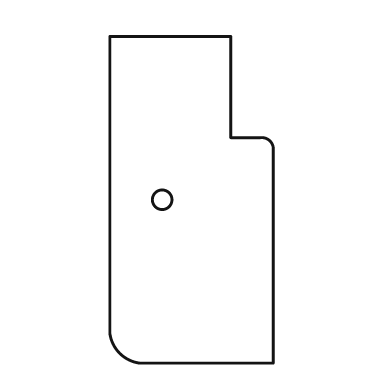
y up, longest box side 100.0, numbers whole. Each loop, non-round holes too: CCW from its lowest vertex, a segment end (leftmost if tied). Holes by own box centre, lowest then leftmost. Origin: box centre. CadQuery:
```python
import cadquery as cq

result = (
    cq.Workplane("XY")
    .moveTo(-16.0, -50.0)
    .lineTo(25.0, -50.0)
    .lineTo(25.0, 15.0)
    .threePointArc((24.0, 18.0), (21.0, 19.0))
    .lineTo(12.0, 19.0)
    .lineTo(12.0, 50.0)
    .lineTo(-25.0, 50.0)
    .lineTo(-25.0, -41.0)
    .threePointArc((-22.0, -47.0), (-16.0, -50.0))
    .close()
    .moveTo(-9.0, 0.0)
    .circle(3.0)
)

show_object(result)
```